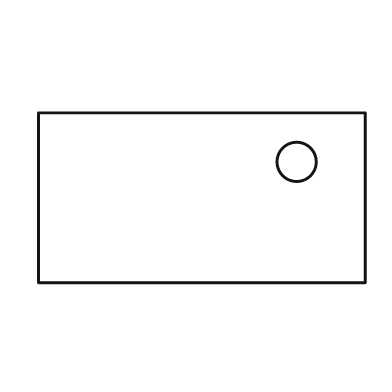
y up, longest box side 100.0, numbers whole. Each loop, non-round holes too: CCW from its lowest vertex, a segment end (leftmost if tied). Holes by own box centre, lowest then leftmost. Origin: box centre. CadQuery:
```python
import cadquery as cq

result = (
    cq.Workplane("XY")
    .moveTo(-50.0, -26.0)
    .lineTo(50.0, -26.0)
    .lineTo(50.0, 26.0)
    .lineTo(-50.0, 26.0)
    .close()
    .moveTo(29.0, 11.0)
    .circle(6.0)
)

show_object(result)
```